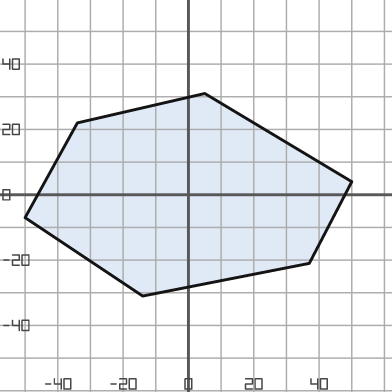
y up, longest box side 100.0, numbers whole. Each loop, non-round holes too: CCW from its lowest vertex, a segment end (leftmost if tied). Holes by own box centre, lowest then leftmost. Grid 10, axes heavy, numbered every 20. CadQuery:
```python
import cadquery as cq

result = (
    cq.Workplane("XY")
    .moveTo(-14.0, -31.0)
    .lineTo(37.0, -21.0)
    .lineTo(50.0, 4.0)
    .lineTo(5.0, 31.0)
    .lineTo(-34.0, 22.0)
    .lineTo(-50.0, -7.0)
    .close()
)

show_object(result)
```